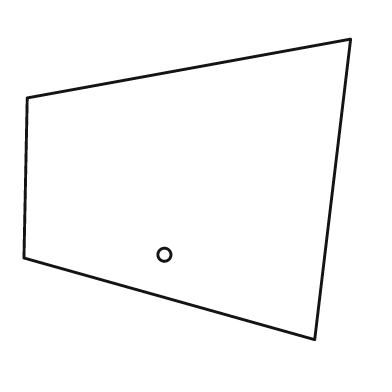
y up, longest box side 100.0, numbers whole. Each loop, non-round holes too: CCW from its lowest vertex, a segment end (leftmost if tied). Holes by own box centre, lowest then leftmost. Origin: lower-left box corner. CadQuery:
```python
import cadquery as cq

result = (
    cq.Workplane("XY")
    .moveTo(89.0, 0.0)
    .lineTo(100.0, 92.0)
    .lineTo(1.0, 74.0)
    .lineTo(0.0, 25.0)
    .close()
    .moveTo(43.0, 26.0)
    .circle(2.0)
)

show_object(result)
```